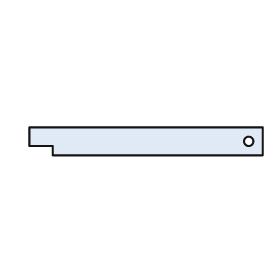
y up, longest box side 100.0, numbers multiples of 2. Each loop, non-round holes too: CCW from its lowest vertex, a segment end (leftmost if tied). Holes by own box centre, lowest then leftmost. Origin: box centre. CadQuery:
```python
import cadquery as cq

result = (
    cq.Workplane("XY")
    .moveTo(-40.0, -6.0)
    .lineTo(50.0, -6.0)
    .lineTo(50.0, 6.0)
    .lineTo(-50.0, 6.0)
    .lineTo(-50.0, -2.0)
    .lineTo(-40.0, -2.0)
    .close()
    .moveTo(44.0, 0.0)
    .circle(2.0)
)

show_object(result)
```